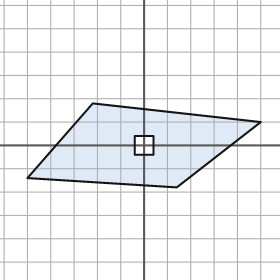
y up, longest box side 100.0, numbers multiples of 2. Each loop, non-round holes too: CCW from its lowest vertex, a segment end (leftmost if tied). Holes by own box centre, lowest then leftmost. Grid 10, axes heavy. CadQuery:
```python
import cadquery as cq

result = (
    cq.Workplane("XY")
    .moveTo(14.0, -18.0)
    .lineTo(50.0, 10.0)
    .lineTo(-22.0, 18.0)
    .lineTo(-50.0, -14.0)
    .close()
    .moveTo(-4.0, -4.0)
    .lineTo(4.0, -4.0)
    .lineTo(4.0, 4.0)
    .lineTo(-4.0, 4.0)
    .close()
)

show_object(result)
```